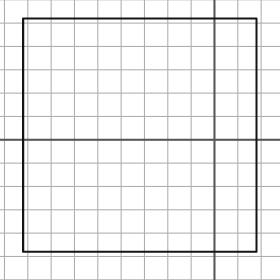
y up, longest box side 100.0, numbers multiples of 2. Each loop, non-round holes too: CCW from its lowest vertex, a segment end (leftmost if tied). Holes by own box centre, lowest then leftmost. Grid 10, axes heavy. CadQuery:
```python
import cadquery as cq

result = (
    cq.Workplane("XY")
    .moveTo(-82.0, -48.0)
    .lineTo(18.0, -48.0)
    .lineTo(18.0, 52.0)
    .lineTo(-82.0, 52.0)
    .close()
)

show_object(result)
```